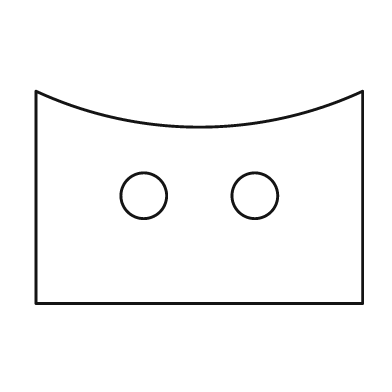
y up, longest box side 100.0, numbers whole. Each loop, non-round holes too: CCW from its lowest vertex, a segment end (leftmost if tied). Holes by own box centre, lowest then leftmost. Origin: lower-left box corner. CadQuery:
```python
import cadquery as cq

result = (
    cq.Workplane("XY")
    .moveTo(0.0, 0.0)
    .lineTo(100.0, 0.0)
    .lineTo(100.0, 65.0)
    .threePointArc((50.0, 54.0), (0.0, 65.0))
    .close()
    .moveTo(33.0, 33.0)
    .circle(7.0)
    .moveTo(67.0, 33.0)
    .circle(7.0)
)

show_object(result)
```